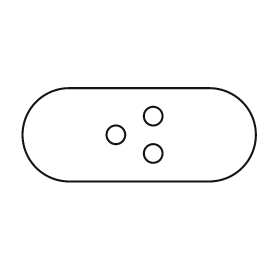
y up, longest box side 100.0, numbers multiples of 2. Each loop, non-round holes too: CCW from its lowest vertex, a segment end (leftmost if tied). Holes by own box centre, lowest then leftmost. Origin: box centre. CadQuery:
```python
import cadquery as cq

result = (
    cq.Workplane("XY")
    .moveTo(-30.0, -20.0)
    .lineTo(30.0, -20.0)
    .threePointArc((50.0, 0.0), (30.0, 20.0))
    .lineTo(-30.0, 20.0)
    .threePointArc((-50.0, 0.0), (-30.0, -20.0))
    .close()
    .moveTo(6.0, -8.0)
    .circle(4.0)
    .moveTo(-10.0, 0.0)
    .circle(4.0)
    .moveTo(6.0, 8.0)
    .circle(4.0)
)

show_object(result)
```